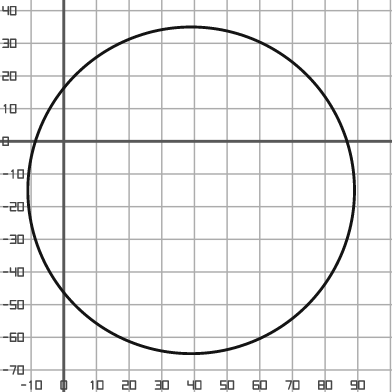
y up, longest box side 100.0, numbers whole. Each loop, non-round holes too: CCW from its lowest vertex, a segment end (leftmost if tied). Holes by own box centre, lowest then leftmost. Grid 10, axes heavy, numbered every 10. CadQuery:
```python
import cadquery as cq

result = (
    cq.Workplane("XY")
    .moveTo(39.0, -15.0)
    .circle(50.0)
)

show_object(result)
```